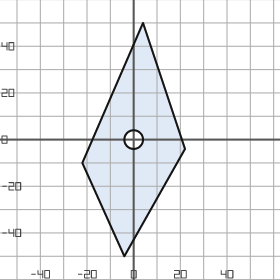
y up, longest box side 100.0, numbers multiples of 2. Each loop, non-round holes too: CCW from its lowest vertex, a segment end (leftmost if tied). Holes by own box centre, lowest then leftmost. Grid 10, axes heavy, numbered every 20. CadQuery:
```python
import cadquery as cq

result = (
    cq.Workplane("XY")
    .moveTo(-4.0, -50.0)
    .lineTo(22.0, -4.0)
    .lineTo(4.0, 50.0)
    .lineTo(-22.0, -10.0)
    .close()
    .moveTo(0.0, 0.0)
    .circle(4.0)
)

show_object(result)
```